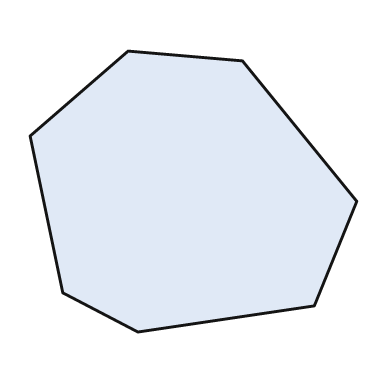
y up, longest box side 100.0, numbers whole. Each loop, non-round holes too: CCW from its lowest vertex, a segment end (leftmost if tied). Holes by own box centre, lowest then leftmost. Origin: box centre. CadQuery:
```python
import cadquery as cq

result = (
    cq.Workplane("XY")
    .moveTo(-17.0, -43.0)
    .lineTo(37.0, -35.0)
    .lineTo(50.0, -3.0)
    .lineTo(15.0, 40.0)
    .lineTo(-20.0, 43.0)
    .lineTo(-50.0, 17.0)
    .lineTo(-40.0, -31.0)
    .close()
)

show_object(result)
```